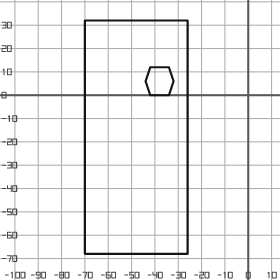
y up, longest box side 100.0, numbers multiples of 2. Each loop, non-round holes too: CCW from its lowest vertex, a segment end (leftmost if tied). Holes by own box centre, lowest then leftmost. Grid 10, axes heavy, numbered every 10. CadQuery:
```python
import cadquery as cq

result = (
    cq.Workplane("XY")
    .moveTo(-70.0, -68.0)
    .lineTo(-26.0, -68.0)
    .lineTo(-26.0, 32.0)
    .lineTo(-70.0, 32.0)
    .close()
    .moveTo(-42.0, 0.0)
    .lineTo(-34.0, 0.0)
    .lineTo(-32.0, 6.0)
    .lineTo(-34.0, 12.0)
    .lineTo(-42.0, 12.0)
    .lineTo(-44.0, 6.0)
    .close()
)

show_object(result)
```